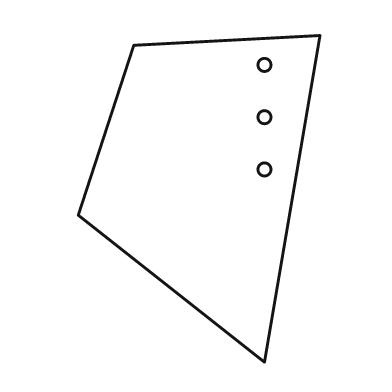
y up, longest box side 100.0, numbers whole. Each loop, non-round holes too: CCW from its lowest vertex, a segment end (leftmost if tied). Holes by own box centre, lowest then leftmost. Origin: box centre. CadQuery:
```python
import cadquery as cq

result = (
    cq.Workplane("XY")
    .moveTo(20.0, -50.0)
    .lineTo(37.0, 50.0)
    .lineTo(-20.0, 47.0)
    .lineTo(-37.0, -5.0)
    .close()
    .moveTo(20.0, 9.0)
    .circle(2.0)
    .moveTo(20.0, 25.0)
    .circle(2.0)
    .moveTo(20.0, 41.0)
    .circle(2.0)
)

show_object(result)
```